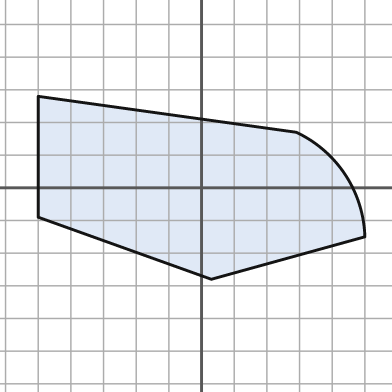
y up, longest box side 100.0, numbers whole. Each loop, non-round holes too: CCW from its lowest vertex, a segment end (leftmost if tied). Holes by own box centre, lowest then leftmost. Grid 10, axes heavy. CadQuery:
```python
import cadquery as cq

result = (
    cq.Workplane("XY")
    .moveTo(3.0, -28.0)
    .lineTo(50.0, -15.0)
    .threePointArc((44.0, 4.0), (29.0, 17.0))
    .lineTo(-50.0, 28.0)
    .lineTo(-50.0, -9.0)
    .close()
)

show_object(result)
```